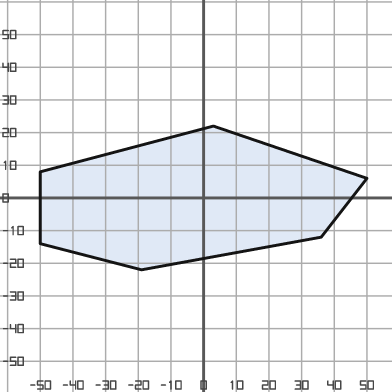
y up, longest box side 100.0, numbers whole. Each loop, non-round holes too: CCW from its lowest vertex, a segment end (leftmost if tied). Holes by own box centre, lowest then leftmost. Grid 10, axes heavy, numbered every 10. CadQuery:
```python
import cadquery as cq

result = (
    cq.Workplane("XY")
    .moveTo(-19.0, -22.0)
    .lineTo(36.0, -12.0)
    .lineTo(50.0, 6.0)
    .lineTo(3.0, 22.0)
    .lineTo(-50.0, 8.0)
    .lineTo(-50.0, -14.0)
    .close()
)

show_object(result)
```